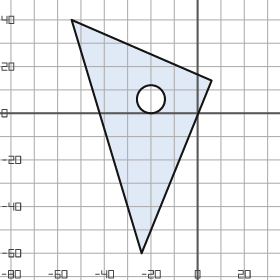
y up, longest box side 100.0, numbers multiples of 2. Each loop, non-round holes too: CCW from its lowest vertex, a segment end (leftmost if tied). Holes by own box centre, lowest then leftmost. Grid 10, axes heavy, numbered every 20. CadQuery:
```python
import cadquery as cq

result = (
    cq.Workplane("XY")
    .moveTo(-24.0, -60.0)
    .lineTo(6.0, 14.0)
    .lineTo(-54.0, 40.0)
    .close()
    .moveTo(-20.0, 6.0)
    .circle(6.0)
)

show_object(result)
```